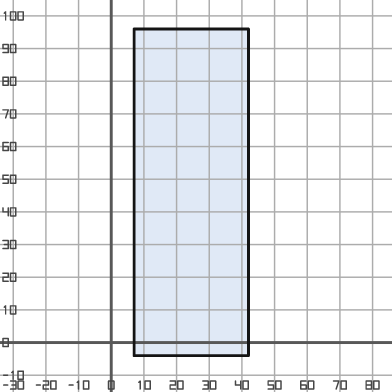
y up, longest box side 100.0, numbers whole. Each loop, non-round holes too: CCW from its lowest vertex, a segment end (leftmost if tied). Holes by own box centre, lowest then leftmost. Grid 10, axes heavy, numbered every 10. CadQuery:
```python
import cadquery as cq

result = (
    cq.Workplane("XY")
    .moveTo(7.0, -4.0)
    .lineTo(42.0, -4.0)
    .lineTo(42.0, 96.0)
    .lineTo(7.0, 96.0)
    .close()
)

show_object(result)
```